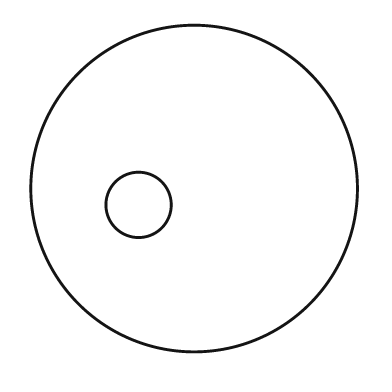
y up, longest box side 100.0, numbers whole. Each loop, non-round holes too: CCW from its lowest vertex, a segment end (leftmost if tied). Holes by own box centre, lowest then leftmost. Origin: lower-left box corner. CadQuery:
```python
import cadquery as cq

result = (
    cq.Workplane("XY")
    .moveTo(50.0, 50.0)
    .circle(50.0)
    .moveTo(33.0, 45.0)
    .circle(10.0)
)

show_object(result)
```